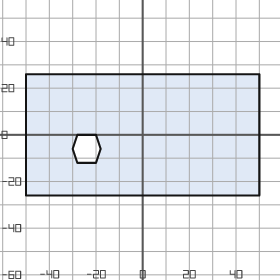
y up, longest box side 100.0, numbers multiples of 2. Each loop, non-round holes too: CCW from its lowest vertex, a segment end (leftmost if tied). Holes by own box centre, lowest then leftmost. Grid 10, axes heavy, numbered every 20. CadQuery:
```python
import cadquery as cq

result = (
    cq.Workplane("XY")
    .moveTo(-50.0, -26.0)
    .lineTo(50.0, -26.0)
    .lineTo(50.0, 26.0)
    .lineTo(-50.0, 26.0)
    .close()
    .moveTo(-28.0, -12.0)
    .lineTo(-20.0, -12.0)
    .lineTo(-18.0, -6.0)
    .lineTo(-20.0, 0.0)
    .lineTo(-28.0, 0.0)
    .lineTo(-30.0, -6.0)
    .close()
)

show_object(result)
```